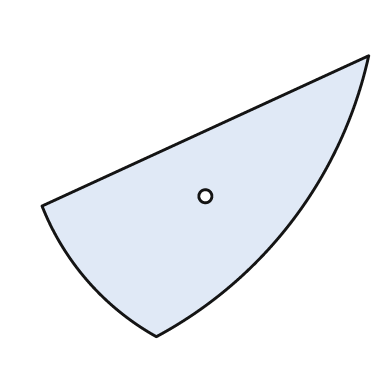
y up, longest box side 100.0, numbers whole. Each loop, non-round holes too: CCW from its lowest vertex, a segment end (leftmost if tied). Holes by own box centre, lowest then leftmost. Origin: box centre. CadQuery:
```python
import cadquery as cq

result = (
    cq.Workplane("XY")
    .moveTo(-15.0, -43.0)
    .threePointArc((27.0, -7.0), (50.0, 43.0))
    .lineTo(-50.0, -3.0)
    .threePointArc((-36.0, -26.0), (-15.0, -43.0))
    .close()
    .moveTo(0.0, 0.0)
    .circle(2.0)
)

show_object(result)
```